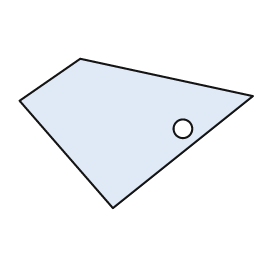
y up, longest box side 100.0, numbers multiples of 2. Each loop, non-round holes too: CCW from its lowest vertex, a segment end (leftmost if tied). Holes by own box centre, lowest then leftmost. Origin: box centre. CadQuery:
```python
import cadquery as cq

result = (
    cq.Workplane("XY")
    .moveTo(-10.0, -32.0)
    .lineTo(50.0, 16.0)
    .lineTo(-24.0, 32.0)
    .lineTo(-50.0, 14.0)
    .close()
    .moveTo(20.0, 2.0)
    .circle(4.0)
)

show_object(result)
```